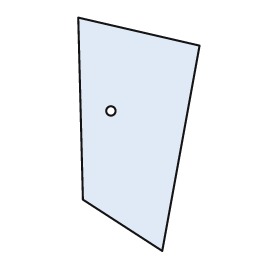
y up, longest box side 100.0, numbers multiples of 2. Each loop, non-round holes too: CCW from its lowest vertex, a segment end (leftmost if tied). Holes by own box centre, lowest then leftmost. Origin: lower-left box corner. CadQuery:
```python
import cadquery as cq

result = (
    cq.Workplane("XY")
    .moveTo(36.0, 0.0)
    .lineTo(52.0, 88.0)
    .lineTo(0.0, 100.0)
    .lineTo(2.0, 22.0)
    .close()
    .moveTo(14.0, 60.0)
    .circle(2.0)
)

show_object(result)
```